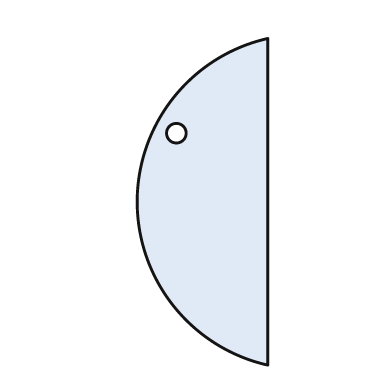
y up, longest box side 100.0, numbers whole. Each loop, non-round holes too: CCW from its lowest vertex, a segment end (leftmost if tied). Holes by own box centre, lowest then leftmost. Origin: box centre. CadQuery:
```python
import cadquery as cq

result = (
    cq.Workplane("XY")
    .moveTo(20.0, -50.0)
    .lineTo(20.0, 50.0)
    .threePointArc((-20.0, 0.0), (20.0, -50.0))
    .close()
    .moveTo(-8.0, 21.0)
    .circle(3.0)
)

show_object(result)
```